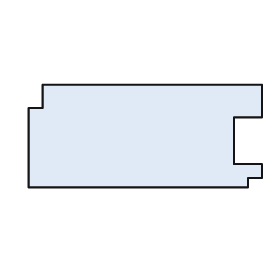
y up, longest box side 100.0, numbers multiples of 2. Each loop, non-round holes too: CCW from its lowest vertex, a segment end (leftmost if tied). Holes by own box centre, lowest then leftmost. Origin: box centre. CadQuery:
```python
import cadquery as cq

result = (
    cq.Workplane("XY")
    .moveTo(-50.0, -22.0)
    .lineTo(44.0, -22.0)
    .lineTo(44.0, -18.0)
    .lineTo(50.0, -18.0)
    .lineTo(50.0, -12.0)
    .lineTo(38.0, -12.0)
    .lineTo(38.0, 8.0)
    .lineTo(50.0, 8.0)
    .lineTo(50.0, 22.0)
    .lineTo(-44.0, 22.0)
    .lineTo(-44.0, 12.0)
    .lineTo(-50.0, 12.0)
    .close()
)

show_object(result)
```